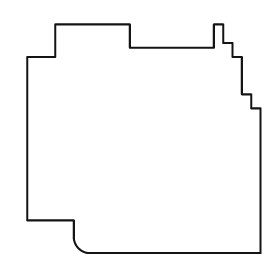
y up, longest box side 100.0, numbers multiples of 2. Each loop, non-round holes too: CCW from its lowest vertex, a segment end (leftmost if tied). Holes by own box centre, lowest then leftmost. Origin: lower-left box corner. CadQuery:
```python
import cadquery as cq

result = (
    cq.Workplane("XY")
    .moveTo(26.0, 0.0)
    .lineTo(100.0, 0.0)
    .lineTo(100.0, 62.0)
    .lineTo(96.0, 62.0)
    .lineTo(96.0, 68.0)
    .lineTo(92.0, 68.0)
    .lineTo(92.0, 84.0)
    .lineTo(88.0, 84.0)
    .lineTo(88.0, 90.0)
    .lineTo(84.0, 90.0)
    .lineTo(84.0, 98.0)
    .lineTo(80.0, 98.0)
    .lineTo(80.0, 88.0)
    .lineTo(44.0, 88.0)
    .lineTo(44.0, 98.0)
    .lineTo(12.0, 98.0)
    .lineTo(12.0, 84.0)
    .lineTo(0.0, 84.0)
    .lineTo(0.0, 14.0)
    .lineTo(20.0, 14.0)
    .lineTo(20.0, 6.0)
    .threePointArc((22.0, 2.0), (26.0, 0.0))
    .close()
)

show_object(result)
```